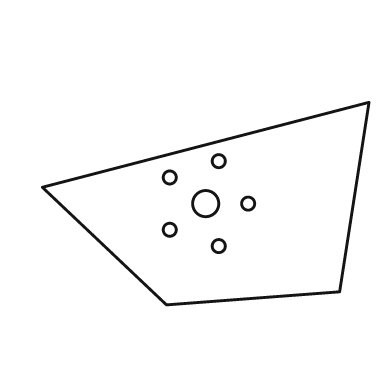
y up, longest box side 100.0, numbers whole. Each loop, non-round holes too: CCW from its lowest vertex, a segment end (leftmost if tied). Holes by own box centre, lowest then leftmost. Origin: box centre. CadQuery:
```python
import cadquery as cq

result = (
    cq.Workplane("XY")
    .moveTo(-12.0, -31.0)
    .lineTo(41.0, -27.0)
    .lineTo(50.0, 31.0)
    .lineTo(-50.0, 5.0)
    .close()
    .moveTo(4.0, -13.0)
    .circle(2.0)
    .moveTo(-11.0, -8.0)
    .circle(2.0)
    .moveTo(0.0, 0.0)
    .circle(4.0)
    .moveTo(13.0, 0.0)
    .circle(2.0)
    .moveTo(-11.0, 8.0)
    .circle(2.0)
    .moveTo(4.0, 13.0)
    .circle(2.0)
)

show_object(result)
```